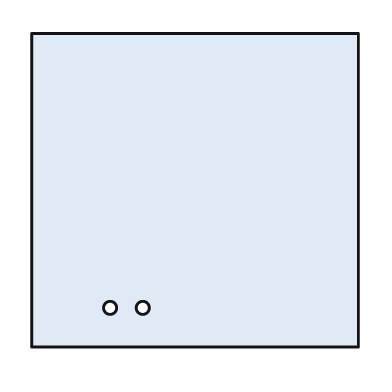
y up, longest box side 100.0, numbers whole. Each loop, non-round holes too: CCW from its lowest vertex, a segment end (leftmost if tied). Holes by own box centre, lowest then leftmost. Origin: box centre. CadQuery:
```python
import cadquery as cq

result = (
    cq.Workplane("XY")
    .moveTo(-50.0, -48.0)
    .lineTo(50.0, -48.0)
    .lineTo(50.0, 48.0)
    .lineTo(-50.0, 48.0)
    .close()
    .moveTo(-26.0, -36.0)
    .circle(2.0)
    .moveTo(-16.0, -36.0)
    .circle(2.0)
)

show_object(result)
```